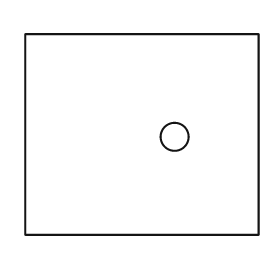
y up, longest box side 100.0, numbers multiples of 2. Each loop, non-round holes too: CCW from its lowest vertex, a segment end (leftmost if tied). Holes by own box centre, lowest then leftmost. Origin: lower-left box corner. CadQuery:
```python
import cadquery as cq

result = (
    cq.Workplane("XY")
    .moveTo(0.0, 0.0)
    .lineTo(100.0, 0.0)
    .lineTo(100.0, 86.0)
    .lineTo(0.0, 86.0)
    .close()
    .moveTo(64.0, 42.0)
    .circle(6.0)
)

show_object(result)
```